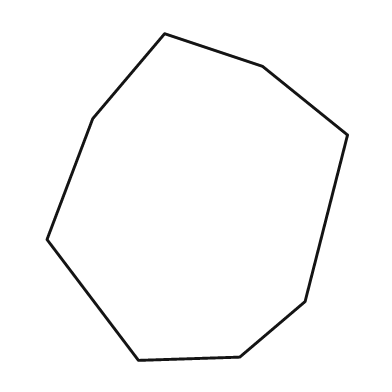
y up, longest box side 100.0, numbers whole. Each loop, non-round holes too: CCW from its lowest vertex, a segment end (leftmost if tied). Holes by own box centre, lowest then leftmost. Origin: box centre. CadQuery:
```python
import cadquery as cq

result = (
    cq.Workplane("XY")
    .moveTo(-18.0, -50.0)
    .lineTo(13.0, -49.0)
    .lineTo(33.0, -32.0)
    .lineTo(46.0, 19.0)
    .lineTo(20.0, 40.0)
    .lineTo(-10.0, 50.0)
    .lineTo(-32.0, 24.0)
    .lineTo(-46.0, -13.0)
    .close()
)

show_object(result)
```